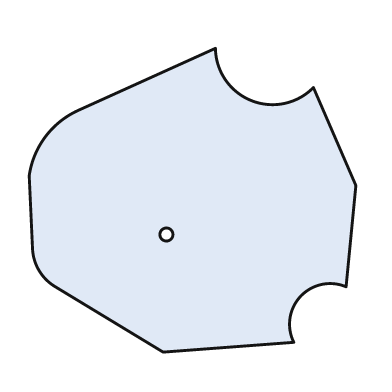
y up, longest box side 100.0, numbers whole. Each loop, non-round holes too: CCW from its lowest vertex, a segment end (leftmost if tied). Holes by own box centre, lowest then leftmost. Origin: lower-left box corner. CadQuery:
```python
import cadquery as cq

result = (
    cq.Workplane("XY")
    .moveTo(41.0, 0.0)
    .lineTo(81.0, 3.0)
    .threePointArc((83.0, 17.0), (97.0, 20.0))
    .lineTo(100.0, 51.0)
    .lineTo(87.0, 81.0)
    .threePointArc((68.0, 77.0), (57.0, 93.0))
    .lineTo(15.0, 74.0)
    .threePointArc((5.0, 66.0), (0.0, 54.0))
    .lineTo(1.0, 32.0)
    .threePointArc((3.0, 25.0), (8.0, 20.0))
    .close()
    .moveTo(42.0, 36.0)
    .circle(2.0)
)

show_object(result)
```